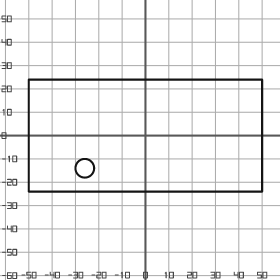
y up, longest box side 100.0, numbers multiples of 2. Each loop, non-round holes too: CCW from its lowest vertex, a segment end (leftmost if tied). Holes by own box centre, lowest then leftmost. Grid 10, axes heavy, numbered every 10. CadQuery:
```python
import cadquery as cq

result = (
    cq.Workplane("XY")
    .moveTo(-50.0, -24.0)
    .lineTo(50.0, -24.0)
    .lineTo(50.0, 24.0)
    .lineTo(-50.0, 24.0)
    .close()
    .moveTo(-26.0, -14.0)
    .circle(4.0)
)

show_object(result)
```